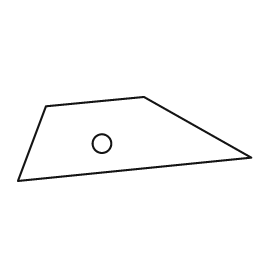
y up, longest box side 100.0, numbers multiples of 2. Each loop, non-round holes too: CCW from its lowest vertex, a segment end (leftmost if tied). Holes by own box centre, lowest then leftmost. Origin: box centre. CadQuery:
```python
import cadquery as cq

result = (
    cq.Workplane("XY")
    .moveTo(-50.0, -18.0)
    .lineTo(50.0, -8.0)
    .lineTo(4.0, 18.0)
    .lineTo(-38.0, 14.0)
    .close()
    .moveTo(-14.0, -2.0)
    .circle(4.0)
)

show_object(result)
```